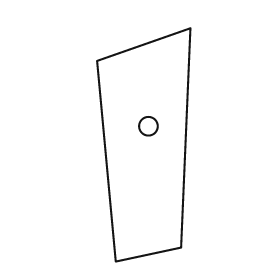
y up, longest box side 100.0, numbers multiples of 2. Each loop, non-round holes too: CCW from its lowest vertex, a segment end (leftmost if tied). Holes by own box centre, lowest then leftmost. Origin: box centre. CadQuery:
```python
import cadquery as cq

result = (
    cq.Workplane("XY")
    .moveTo(-12.0, -50.0)
    .lineTo(16.0, -44.0)
    .lineTo(20.0, 50.0)
    .lineTo(-20.0, 36.0)
    .close()
    .moveTo(2.0, 8.0)
    .circle(4.0)
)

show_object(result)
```